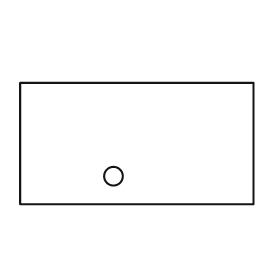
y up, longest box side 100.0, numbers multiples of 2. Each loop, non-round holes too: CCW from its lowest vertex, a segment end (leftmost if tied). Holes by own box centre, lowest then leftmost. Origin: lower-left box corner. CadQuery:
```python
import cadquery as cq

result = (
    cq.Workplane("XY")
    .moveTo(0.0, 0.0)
    .lineTo(100.0, 0.0)
    .lineTo(100.0, 52.0)
    .lineTo(0.0, 52.0)
    .close()
    .moveTo(40.0, 12.0)
    .circle(4.0)
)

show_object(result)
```